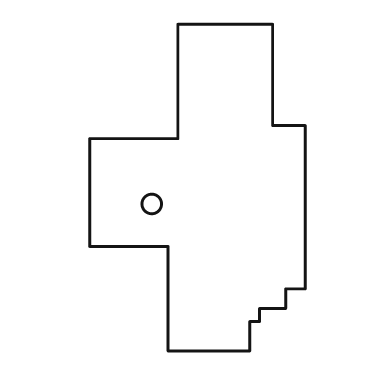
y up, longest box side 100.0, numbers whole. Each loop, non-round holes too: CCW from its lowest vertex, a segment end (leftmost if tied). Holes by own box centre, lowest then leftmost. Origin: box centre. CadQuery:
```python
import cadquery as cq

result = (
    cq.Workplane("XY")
    .moveTo(-9.0, -50.0)
    .lineTo(16.0, -50.0)
    .lineTo(16.0, -41.0)
    .lineTo(19.0, -41.0)
    .lineTo(19.0, -37.0)
    .lineTo(27.0, -37.0)
    .lineTo(27.0, -31.0)
    .lineTo(33.0, -31.0)
    .lineTo(33.0, 19.0)
    .lineTo(23.0, 19.0)
    .lineTo(23.0, 50.0)
    .lineTo(-6.0, 50.0)
    .lineTo(-6.0, 15.0)
    .lineTo(-33.0, 15.0)
    .lineTo(-33.0, -18.0)
    .lineTo(-9.0, -18.0)
    .close()
    .moveTo(-14.0, -5.0)
    .circle(3.0)
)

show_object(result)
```